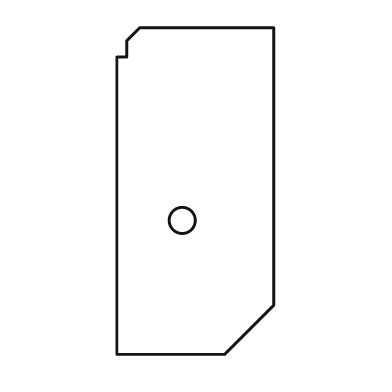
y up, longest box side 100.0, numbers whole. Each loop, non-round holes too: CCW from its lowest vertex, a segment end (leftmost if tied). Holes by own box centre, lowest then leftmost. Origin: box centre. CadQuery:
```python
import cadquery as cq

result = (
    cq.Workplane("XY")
    .moveTo(-24.0, -50.0)
    .lineTo(9.0, -50.0)
    .lineTo(24.0, -35.0)
    .lineTo(24.0, 50.0)
    .lineTo(-17.0, 50.0)
    .lineTo(-21.0, 46.0)
    .lineTo(-21.0, 41.0)
    .lineTo(-24.0, 41.0)
    .close()
    .moveTo(-4.0, -9.0)
    .circle(4.0)
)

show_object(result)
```